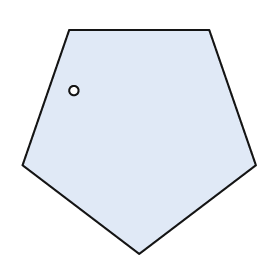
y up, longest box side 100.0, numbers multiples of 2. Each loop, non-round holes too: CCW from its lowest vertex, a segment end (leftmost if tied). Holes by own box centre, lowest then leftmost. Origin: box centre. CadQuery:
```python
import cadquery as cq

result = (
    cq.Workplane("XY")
    .moveTo(0.0, -48.0)
    .lineTo(50.0, -10.0)
    .lineTo(30.0, 48.0)
    .lineTo(-30.0, 48.0)
    .lineTo(-50.0, -10.0)
    .close()
    .moveTo(-28.0, 22.0)
    .circle(2.0)
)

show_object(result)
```